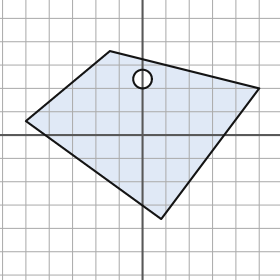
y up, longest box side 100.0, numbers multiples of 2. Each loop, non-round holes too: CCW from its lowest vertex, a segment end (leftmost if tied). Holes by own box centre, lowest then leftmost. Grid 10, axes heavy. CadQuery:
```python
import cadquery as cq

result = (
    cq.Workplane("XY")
    .moveTo(8.0, -36.0)
    .lineTo(50.0, 20.0)
    .lineTo(-14.0, 36.0)
    .lineTo(-50.0, 6.0)
    .close()
    .moveTo(0.0, 24.0)
    .circle(4.0)
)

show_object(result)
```